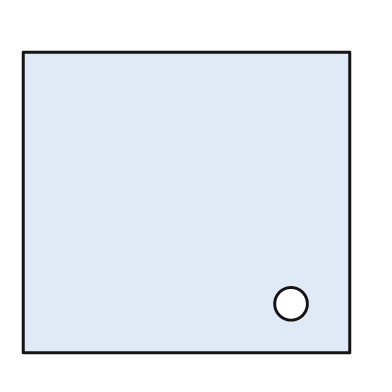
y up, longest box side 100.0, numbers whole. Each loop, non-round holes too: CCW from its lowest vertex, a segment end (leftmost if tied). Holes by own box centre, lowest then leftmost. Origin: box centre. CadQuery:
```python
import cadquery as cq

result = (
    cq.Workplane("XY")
    .moveTo(-50.0, -46.0)
    .lineTo(50.0, -46.0)
    .lineTo(50.0, 46.0)
    .lineTo(-50.0, 46.0)
    .close()
    .moveTo(32.0, -31.0)
    .circle(5.0)
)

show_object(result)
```